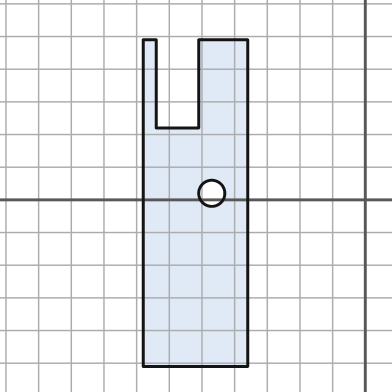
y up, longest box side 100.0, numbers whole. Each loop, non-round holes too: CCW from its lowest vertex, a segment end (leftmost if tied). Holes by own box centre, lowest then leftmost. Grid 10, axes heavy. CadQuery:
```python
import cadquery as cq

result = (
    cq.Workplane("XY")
    .moveTo(-68.0, -51.0)
    .lineTo(-36.0, -51.0)
    .lineTo(-36.0, 49.0)
    .lineTo(-51.0, 49.0)
    .lineTo(-51.0, 22.0)
    .lineTo(-64.0, 22.0)
    .lineTo(-64.0, 49.0)
    .lineTo(-68.0, 49.0)
    .close()
    .moveTo(-47.0, 2.0)
    .circle(4.0)
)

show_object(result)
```